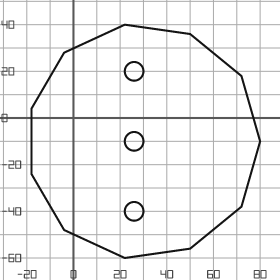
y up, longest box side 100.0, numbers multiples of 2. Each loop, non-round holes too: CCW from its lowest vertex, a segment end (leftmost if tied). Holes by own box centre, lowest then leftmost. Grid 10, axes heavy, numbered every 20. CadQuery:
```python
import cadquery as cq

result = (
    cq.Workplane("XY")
    .moveTo(22.0, -60.0)
    .lineTo(50.0, -56.0)
    .lineTo(72.0, -38.0)
    .lineTo(80.0, -10.0)
    .lineTo(72.0, 18.0)
    .lineTo(50.0, 36.0)
    .lineTo(22.0, 40.0)
    .lineTo(-4.0, 28.0)
    .lineTo(-18.0, 4.0)
    .lineTo(-18.0, -24.0)
    .lineTo(-4.0, -48.0)
    .close()
    .moveTo(26.0, -40.0)
    .circle(4.0)
    .moveTo(26.0, -10.0)
    .circle(4.0)
    .moveTo(26.0, 20.0)
    .circle(4.0)
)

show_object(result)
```